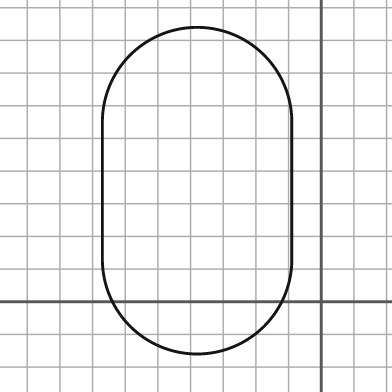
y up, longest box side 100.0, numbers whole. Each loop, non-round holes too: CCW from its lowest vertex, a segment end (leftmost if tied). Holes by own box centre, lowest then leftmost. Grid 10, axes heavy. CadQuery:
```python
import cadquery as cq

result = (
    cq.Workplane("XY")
    .moveTo(-67.0, 13.0)
    .threePointArc((-38.0, -16.0), (-9.0, 13.0))
    .lineTo(-9.0, 55.0)
    .threePointArc((-38.0, 84.0), (-67.0, 55.0))
    .close()
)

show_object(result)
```